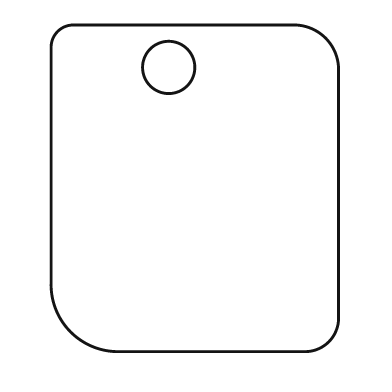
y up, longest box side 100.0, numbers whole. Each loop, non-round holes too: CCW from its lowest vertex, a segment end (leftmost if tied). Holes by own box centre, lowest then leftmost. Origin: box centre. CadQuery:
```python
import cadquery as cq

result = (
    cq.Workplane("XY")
    .moveTo(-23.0, -50.0)
    .lineTo(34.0, -50.0)
    .threePointArc((41.0, -47.0), (44.0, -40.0))
    .lineTo(44.0, 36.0)
    .threePointArc((40.0, 46.0), (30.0, 50.0))
    .lineTo(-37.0, 50.0)
    .threePointArc((-42.0, 48.0), (-44.0, 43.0))
    .lineTo(-44.0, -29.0)
    .threePointArc((-38.0, -44.0), (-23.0, -50.0))
    .close()
    .moveTo(-8.0, 37.0)
    .circle(8.0)
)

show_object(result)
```